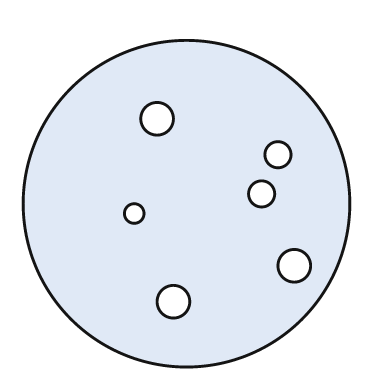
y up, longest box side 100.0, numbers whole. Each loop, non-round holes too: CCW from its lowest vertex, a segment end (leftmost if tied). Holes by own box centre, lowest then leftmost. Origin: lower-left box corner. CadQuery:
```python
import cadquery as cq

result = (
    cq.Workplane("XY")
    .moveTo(50.0, 50.0)
    .circle(50.0)
    .moveTo(46.0, 20.0)
    .circle(5.0)
    .moveTo(83.0, 31.0)
    .circle(5.0)
    .moveTo(34.0, 47.0)
    .circle(3.0)
    .moveTo(73.0, 53.0)
    .circle(4.0)
    .moveTo(78.0, 65.0)
    .circle(4.0)
    .moveTo(41.0, 76.0)
    .circle(5.0)
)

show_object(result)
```